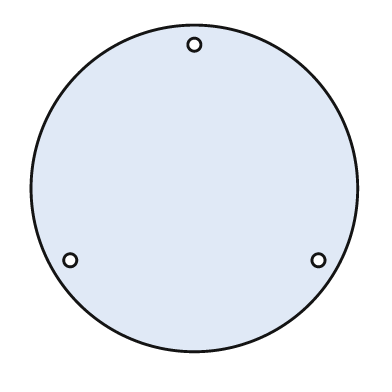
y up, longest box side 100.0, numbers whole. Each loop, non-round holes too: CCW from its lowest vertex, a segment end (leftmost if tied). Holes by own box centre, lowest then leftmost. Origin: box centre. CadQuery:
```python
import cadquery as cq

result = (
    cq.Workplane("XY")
    .moveTo(0.0, 0.0)
    .circle(50.0)
    .moveTo(-38.0, -22.0)
    .circle(2.0)
    .moveTo(38.0, -22.0)
    .circle(2.0)
    .moveTo(0.0, 44.0)
    .circle(2.0)
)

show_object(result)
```